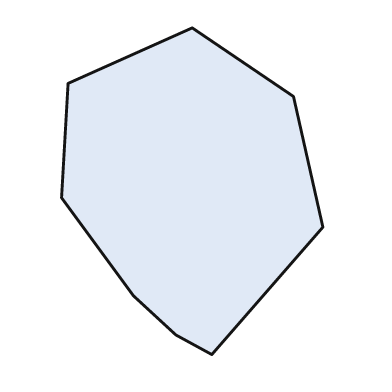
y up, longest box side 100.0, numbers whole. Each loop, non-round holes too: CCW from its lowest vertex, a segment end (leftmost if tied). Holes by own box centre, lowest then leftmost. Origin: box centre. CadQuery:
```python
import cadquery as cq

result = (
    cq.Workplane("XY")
    .moveTo(6.0, -50.0)
    .lineTo(40.0, -11.0)
    .lineTo(31.0, 29.0)
    .lineTo(0.0, 50.0)
    .lineTo(-38.0, 33.0)
    .lineTo(-40.0, -2.0)
    .lineTo(-18.0, -32.0)
    .lineTo(-5.0, -44.0)
    .close()
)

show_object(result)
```